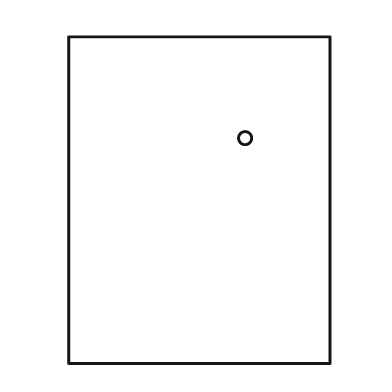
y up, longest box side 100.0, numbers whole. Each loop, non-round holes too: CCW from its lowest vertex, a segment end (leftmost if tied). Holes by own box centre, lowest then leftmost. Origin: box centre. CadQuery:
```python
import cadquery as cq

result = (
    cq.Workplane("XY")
    .moveTo(-40.0, -50.0)
    .lineTo(40.0, -50.0)
    .lineTo(40.0, 50.0)
    .lineTo(-40.0, 50.0)
    .close()
    .moveTo(14.0, 19.0)
    .circle(2.0)
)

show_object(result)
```